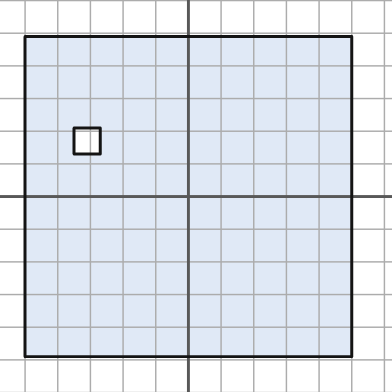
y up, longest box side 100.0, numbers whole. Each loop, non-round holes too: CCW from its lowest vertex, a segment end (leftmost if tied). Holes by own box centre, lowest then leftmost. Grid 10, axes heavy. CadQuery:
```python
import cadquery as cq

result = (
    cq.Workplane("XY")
    .moveTo(-50.0, -49.0)
    .lineTo(50.0, -49.0)
    .lineTo(50.0, 49.0)
    .lineTo(-50.0, 49.0)
    .close()
    .moveTo(-35.0, 13.0)
    .lineTo(-27.0, 13.0)
    .lineTo(-27.0, 21.0)
    .lineTo(-35.0, 21.0)
    .close()
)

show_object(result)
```